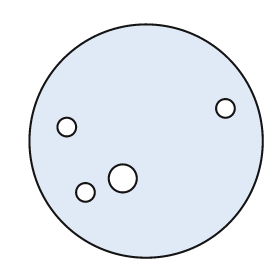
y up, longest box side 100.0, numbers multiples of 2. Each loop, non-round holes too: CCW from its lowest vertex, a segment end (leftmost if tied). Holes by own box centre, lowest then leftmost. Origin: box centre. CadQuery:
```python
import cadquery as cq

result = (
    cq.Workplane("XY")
    .moveTo(0.0, 0.0)
    .circle(50.0)
    .moveTo(-26.0, -22.0)
    .circle(4.0)
    .moveTo(-10.0, -16.0)
    .circle(6.0)
    .moveTo(-34.0, 6.0)
    .circle(4.0)
    .moveTo(34.0, 14.0)
    .circle(4.0)
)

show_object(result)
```